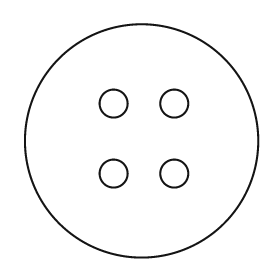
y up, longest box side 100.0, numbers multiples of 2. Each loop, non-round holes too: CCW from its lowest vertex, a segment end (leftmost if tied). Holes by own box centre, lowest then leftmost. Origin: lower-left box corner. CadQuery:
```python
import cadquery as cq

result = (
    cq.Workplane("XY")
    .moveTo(50.0, 50.0)
    .circle(50.0)
    .moveTo(38.0, 36.0)
    .circle(6.0)
    .moveTo(64.0, 36.0)
    .circle(6.0)
    .moveTo(38.0, 66.0)
    .circle(6.0)
    .moveTo(64.0, 66.0)
    .circle(6.0)
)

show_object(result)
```